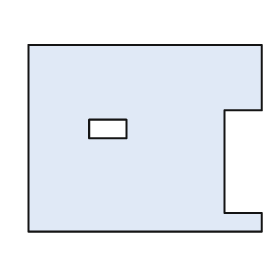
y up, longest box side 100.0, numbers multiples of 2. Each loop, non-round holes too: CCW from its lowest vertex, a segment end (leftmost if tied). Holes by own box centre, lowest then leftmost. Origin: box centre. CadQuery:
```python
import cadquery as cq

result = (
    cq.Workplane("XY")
    .moveTo(-50.0, -40.0)
    .lineTo(50.0, -40.0)
    .lineTo(50.0, -32.0)
    .lineTo(34.0, -32.0)
    .lineTo(34.0, 12.0)
    .lineTo(50.0, 12.0)
    .lineTo(50.0, 40.0)
    .lineTo(-50.0, 40.0)
    .close()
    .moveTo(-24.0, 0.0)
    .lineTo(-8.0, 0.0)
    .lineTo(-8.0, 8.0)
    .lineTo(-24.0, 8.0)
    .close()
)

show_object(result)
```